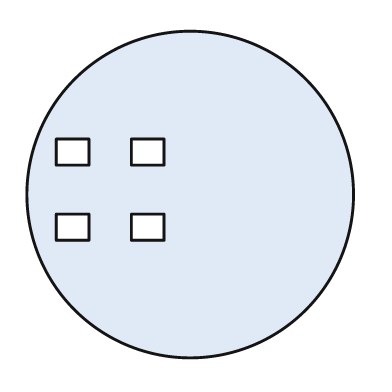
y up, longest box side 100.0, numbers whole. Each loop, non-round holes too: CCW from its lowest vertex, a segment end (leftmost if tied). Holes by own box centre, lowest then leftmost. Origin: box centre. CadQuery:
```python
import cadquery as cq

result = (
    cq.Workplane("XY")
    .moveTo(0.0, 0.0)
    .circle(50.0)
    .moveTo(-41.0, -14.0)
    .lineTo(-31.0, -14.0)
    .lineTo(-31.0, -6.0)
    .lineTo(-41.0, -6.0)
    .close()
    .moveTo(-18.0, -14.0)
    .lineTo(-8.0, -14.0)
    .lineTo(-8.0, -6.0)
    .lineTo(-18.0, -6.0)
    .close()
    .moveTo(-41.0, 9.0)
    .lineTo(-31.0, 9.0)
    .lineTo(-31.0, 17.0)
    .lineTo(-41.0, 17.0)
    .close()
    .moveTo(-18.0, 9.0)
    .lineTo(-8.0, 9.0)
    .lineTo(-8.0, 17.0)
    .lineTo(-18.0, 17.0)
    .close()
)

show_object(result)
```